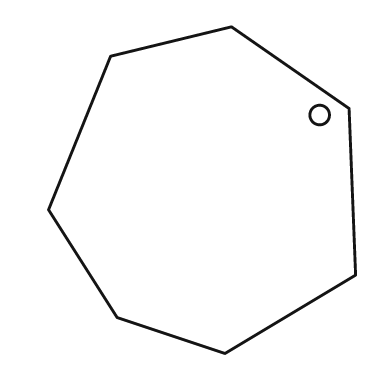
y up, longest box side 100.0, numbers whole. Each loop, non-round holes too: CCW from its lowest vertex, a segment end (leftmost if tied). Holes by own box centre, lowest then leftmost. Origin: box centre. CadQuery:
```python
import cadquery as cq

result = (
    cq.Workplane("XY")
    .moveTo(7.0, -50.0)
    .lineTo(47.0, -26.0)
    .lineTo(45.0, 25.0)
    .lineTo(9.0, 50.0)
    .lineTo(-28.0, 41.0)
    .lineTo(-47.0, -6.0)
    .lineTo(-26.0, -39.0)
    .close()
    .moveTo(36.0, 23.0)
    .circle(3.0)
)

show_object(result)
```